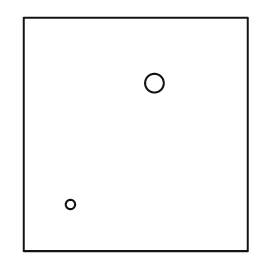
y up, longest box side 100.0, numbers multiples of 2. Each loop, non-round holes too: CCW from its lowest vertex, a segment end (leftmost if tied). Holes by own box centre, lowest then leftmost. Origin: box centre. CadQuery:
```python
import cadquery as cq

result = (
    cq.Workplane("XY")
    .moveTo(-48.0, -50.0)
    .lineTo(48.0, -50.0)
    .lineTo(48.0, 50.0)
    .lineTo(-48.0, 50.0)
    .close()
    .moveTo(-28.0, -30.0)
    .circle(2.0)
    .moveTo(8.0, 22.0)
    .circle(4.0)
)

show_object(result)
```